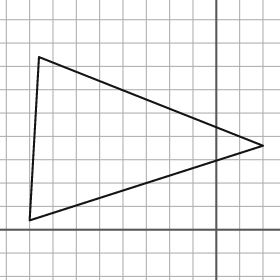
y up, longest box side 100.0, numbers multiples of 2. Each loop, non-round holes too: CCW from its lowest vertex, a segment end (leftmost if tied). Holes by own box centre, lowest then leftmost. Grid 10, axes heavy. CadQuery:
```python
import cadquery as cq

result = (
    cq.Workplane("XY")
    .moveTo(-80.0, 4.0)
    .lineTo(20.0, 36.0)
    .lineTo(-76.0, 74.0)
    .close()
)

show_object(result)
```